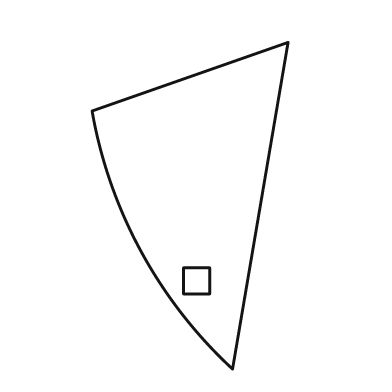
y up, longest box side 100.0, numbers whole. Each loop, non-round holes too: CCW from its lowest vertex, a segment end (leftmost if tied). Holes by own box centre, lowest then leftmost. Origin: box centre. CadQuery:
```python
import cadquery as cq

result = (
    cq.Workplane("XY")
    .moveTo(13.0, -50.0)
    .lineTo(30.0, 50.0)
    .lineTo(-30.0, 29.0)
    .threePointArc((-15.0, -14.0), (13.0, -50.0))
    .close()
    .moveTo(-2.0, -27.0)
    .lineTo(6.0, -27.0)
    .lineTo(6.0, -19.0)
    .lineTo(-2.0, -19.0)
    .close()
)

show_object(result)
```